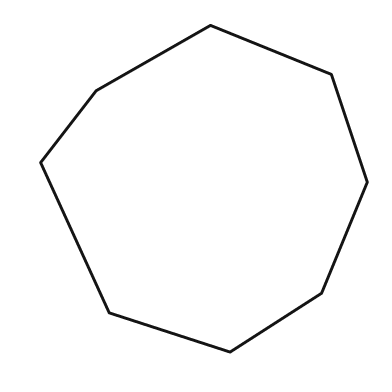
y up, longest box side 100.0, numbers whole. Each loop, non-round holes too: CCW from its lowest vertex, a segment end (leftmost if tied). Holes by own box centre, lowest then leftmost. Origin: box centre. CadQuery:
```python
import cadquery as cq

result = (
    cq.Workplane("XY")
    .moveTo(8.0, -50.0)
    .lineTo(36.0, -32.0)
    .lineTo(50.0, 2.0)
    .lineTo(39.0, 35.0)
    .lineTo(2.0, 50.0)
    .lineTo(-33.0, 30.0)
    .lineTo(-50.0, 8.0)
    .lineTo(-29.0, -38.0)
    .close()
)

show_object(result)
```